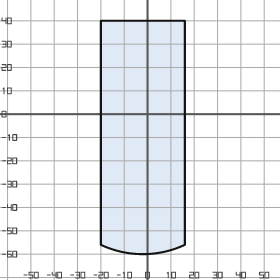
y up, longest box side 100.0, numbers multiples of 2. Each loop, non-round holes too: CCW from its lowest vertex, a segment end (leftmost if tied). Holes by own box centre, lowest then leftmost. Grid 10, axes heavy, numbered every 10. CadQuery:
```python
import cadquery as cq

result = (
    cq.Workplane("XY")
    .moveTo(-20.0, -56.0)
    .threePointArc((-2.0, -60.0), (16.0, -56.0))
    .lineTo(16.0, 40.0)
    .lineTo(-20.0, 40.0)
    .close()
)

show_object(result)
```